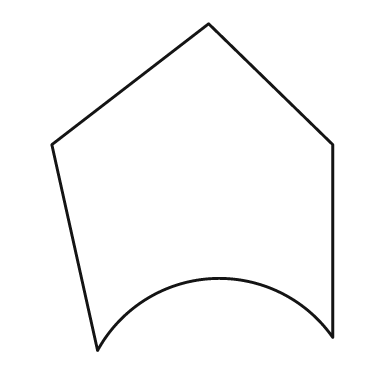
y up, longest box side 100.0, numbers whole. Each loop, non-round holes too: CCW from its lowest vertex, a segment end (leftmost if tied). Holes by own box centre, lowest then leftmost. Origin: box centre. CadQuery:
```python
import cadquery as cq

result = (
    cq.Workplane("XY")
    .moveTo(-29.0, -50.0)
    .threePointArc((6.0, -28.0), (43.0, -46.0))
    .lineTo(43.0, 13.0)
    .lineTo(5.0, 50.0)
    .lineTo(-43.0, 13.0)
    .close()
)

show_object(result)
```